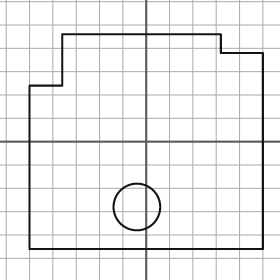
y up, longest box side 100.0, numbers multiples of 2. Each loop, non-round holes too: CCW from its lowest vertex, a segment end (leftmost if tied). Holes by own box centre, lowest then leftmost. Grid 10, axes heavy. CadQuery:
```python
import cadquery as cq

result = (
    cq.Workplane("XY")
    .moveTo(-50.0, -46.0)
    .lineTo(50.0, -46.0)
    .lineTo(50.0, 38.0)
    .lineTo(32.0, 38.0)
    .lineTo(32.0, 46.0)
    .lineTo(-36.0, 46.0)
    .lineTo(-36.0, 24.0)
    .lineTo(-50.0, 24.0)
    .close()
    .moveTo(-4.0, -28.0)
    .circle(10.0)
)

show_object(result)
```